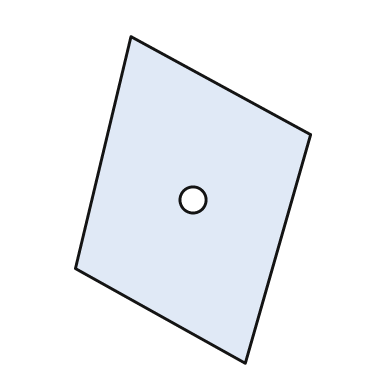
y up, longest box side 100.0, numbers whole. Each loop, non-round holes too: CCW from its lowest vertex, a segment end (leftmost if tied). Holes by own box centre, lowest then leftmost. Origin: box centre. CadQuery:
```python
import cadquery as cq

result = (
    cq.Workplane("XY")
    .moveTo(16.0, -50.0)
    .lineTo(36.0, 20.0)
    .lineTo(-19.0, 50.0)
    .lineTo(-36.0, -21.0)
    .close()
    .moveTo(0.0, 0.0)
    .circle(4.0)
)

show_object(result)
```